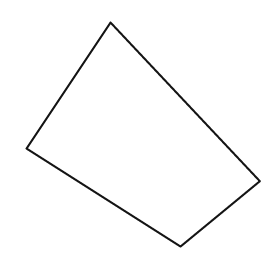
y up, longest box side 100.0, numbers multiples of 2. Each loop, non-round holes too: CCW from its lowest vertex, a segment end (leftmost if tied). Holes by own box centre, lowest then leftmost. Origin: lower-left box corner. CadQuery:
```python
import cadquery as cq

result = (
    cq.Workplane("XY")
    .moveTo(66.0, 0.0)
    .lineTo(100.0, 28.0)
    .lineTo(36.0, 96.0)
    .lineTo(0.0, 42.0)
    .close()
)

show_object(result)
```